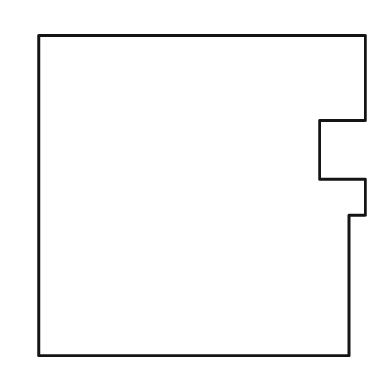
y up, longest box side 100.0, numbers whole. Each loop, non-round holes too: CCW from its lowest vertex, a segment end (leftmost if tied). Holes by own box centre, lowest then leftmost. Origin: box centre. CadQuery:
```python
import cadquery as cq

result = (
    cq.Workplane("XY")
    .moveTo(-50.0, -49.0)
    .lineTo(45.0, -49.0)
    .lineTo(45.0, -6.0)
    .lineTo(50.0, -6.0)
    .lineTo(50.0, 5.0)
    .lineTo(36.0, 5.0)
    .lineTo(36.0, 23.0)
    .lineTo(50.0, 23.0)
    .lineTo(50.0, 49.0)
    .lineTo(-50.0, 49.0)
    .close()
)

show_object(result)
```